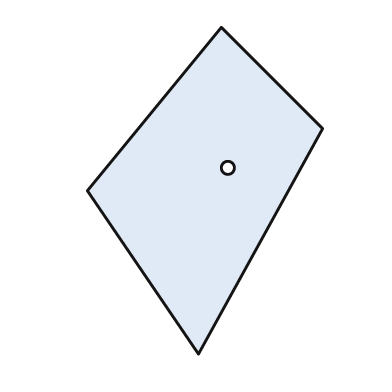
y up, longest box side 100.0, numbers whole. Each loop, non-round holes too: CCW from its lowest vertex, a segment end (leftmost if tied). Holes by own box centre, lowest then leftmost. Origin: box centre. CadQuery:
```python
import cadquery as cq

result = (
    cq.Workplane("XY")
    .moveTo(-2.0, -50.0)
    .lineTo(36.0, 19.0)
    .lineTo(5.0, 50.0)
    .lineTo(-36.0, 0.0)
    .close()
    .moveTo(7.0, 7.0)
    .circle(2.0)
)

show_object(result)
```